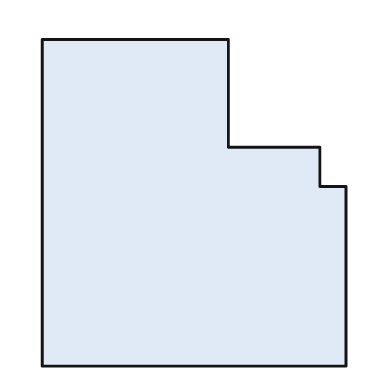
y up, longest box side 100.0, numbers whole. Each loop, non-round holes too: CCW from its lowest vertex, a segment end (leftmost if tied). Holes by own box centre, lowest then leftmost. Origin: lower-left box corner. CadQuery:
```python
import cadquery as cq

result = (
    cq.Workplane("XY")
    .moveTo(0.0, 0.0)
    .lineTo(93.0, 0.0)
    .lineTo(93.0, 55.0)
    .lineTo(85.0, 55.0)
    .lineTo(85.0, 67.0)
    .lineTo(57.0, 67.0)
    .lineTo(57.0, 100.0)
    .lineTo(0.0, 100.0)
    .close()
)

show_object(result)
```